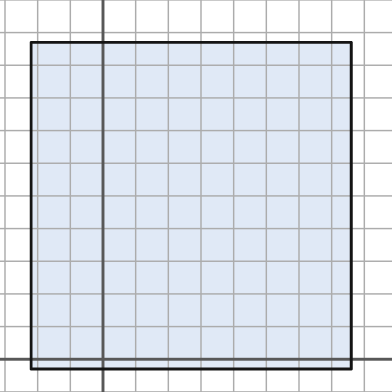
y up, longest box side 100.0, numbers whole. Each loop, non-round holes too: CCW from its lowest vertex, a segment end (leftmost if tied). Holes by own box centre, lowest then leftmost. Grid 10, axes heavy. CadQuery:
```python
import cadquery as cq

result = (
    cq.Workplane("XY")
    .moveTo(-22.0, -3.0)
    .lineTo(76.0, -3.0)
    .lineTo(76.0, 97.0)
    .lineTo(-22.0, 97.0)
    .close()
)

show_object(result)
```